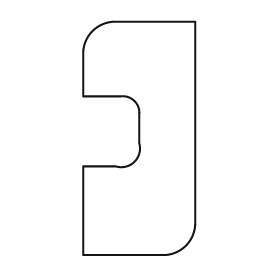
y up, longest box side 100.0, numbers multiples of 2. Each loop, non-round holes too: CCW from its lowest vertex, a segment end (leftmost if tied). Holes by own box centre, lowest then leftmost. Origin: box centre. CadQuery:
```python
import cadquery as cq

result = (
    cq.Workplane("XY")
    .moveTo(-24.0, -50.0)
    .lineTo(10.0, -50.0)
    .threePointArc((20.0, -46.0), (24.0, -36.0))
    .lineTo(24.0, 50.0)
    .lineTo(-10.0, 50.0)
    .threePointArc((-20.0, 46.0), (-24.0, 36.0))
    .lineTo(-24.0, 18.0)
    .lineTo(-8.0, 18.0)
    .threePointArc((-2.0, 16.0), (0.0, 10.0))
    .lineTo(0.0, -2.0)
    .threePointArc((-2.0, -10.0), (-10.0, -12.0))
    .lineTo(-24.0, -12.0)
    .close()
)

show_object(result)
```